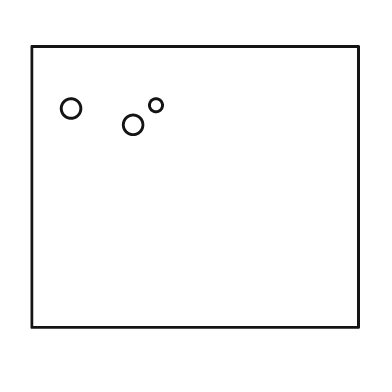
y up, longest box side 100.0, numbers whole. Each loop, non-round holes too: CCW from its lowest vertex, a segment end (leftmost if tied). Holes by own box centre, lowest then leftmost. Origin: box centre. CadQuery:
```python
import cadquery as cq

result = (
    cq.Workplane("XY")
    .moveTo(-50.0, -43.0)
    .lineTo(50.0, -43.0)
    .lineTo(50.0, 43.0)
    .lineTo(-50.0, 43.0)
    .close()
    .moveTo(-19.0, 19.0)
    .circle(3.0)
    .moveTo(-38.0, 24.0)
    .circle(3.0)
    .moveTo(-12.0, 25.0)
    .circle(2.0)
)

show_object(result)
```